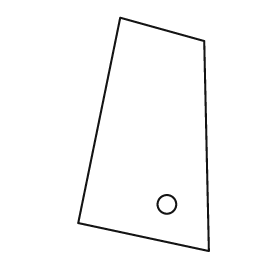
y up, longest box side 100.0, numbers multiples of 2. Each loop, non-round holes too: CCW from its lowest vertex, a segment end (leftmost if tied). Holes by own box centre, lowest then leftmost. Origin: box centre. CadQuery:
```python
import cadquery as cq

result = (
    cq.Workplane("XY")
    .moveTo(28.0, -50.0)
    .lineTo(26.0, 40.0)
    .lineTo(-10.0, 50.0)
    .lineTo(-28.0, -38.0)
    .close()
    .moveTo(10.0, -30.0)
    .circle(4.0)
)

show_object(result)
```